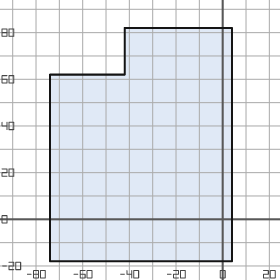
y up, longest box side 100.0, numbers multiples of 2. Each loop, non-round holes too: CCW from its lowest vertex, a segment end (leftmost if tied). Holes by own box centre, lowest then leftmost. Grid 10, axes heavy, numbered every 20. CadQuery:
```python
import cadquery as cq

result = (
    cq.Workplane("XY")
    .moveTo(-74.0, -18.0)
    .lineTo(4.0, -18.0)
    .lineTo(4.0, 82.0)
    .lineTo(-42.0, 82.0)
    .lineTo(-42.0, 62.0)
    .lineTo(-74.0, 62.0)
    .close()
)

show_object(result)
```